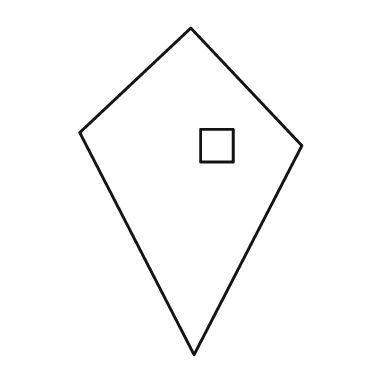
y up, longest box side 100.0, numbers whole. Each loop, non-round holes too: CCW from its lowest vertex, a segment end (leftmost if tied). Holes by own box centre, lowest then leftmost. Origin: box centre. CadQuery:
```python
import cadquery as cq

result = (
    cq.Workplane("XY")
    .moveTo(1.0, -50.0)
    .lineTo(34.0, 14.0)
    .lineTo(0.0, 50.0)
    .lineTo(-34.0, 18.0)
    .close()
    .moveTo(3.0, 9.0)
    .lineTo(13.0, 9.0)
    .lineTo(13.0, 19.0)
    .lineTo(3.0, 19.0)
    .close()
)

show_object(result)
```